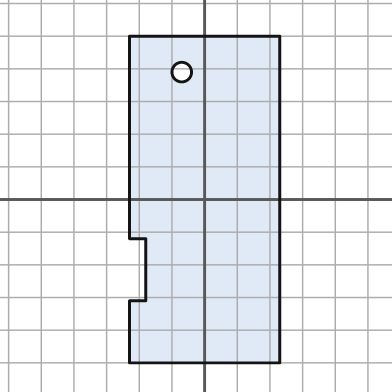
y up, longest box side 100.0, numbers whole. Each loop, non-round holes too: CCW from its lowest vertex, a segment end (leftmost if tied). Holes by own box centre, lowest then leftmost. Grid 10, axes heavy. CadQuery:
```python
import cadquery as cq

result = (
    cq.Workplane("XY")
    .moveTo(-23.0, -50.0)
    .lineTo(23.0, -50.0)
    .lineTo(23.0, 50.0)
    .lineTo(-23.0, 50.0)
    .lineTo(-23.0, -12.0)
    .lineTo(-18.0, -12.0)
    .lineTo(-18.0, -31.0)
    .lineTo(-23.0, -31.0)
    .close()
    .moveTo(-7.0, 39.0)
    .circle(3.0)
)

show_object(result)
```